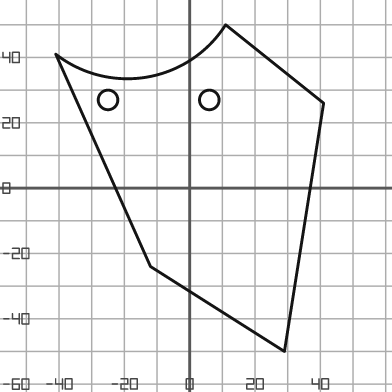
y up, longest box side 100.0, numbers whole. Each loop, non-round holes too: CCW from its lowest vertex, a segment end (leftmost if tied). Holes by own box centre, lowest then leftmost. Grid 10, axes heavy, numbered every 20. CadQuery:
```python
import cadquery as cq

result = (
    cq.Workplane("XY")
    .moveTo(29.0, -50.0)
    .lineTo(41.0, 26.0)
    .lineTo(11.0, 50.0)
    .threePointArc((-13.0, 34.0), (-41.0, 41.0))
    .lineTo(-12.0, -24.0)
    .close()
    .moveTo(-25.0, 27.0)
    .circle(3.0)
    .moveTo(6.0, 27.0)
    .circle(3.0)
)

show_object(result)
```